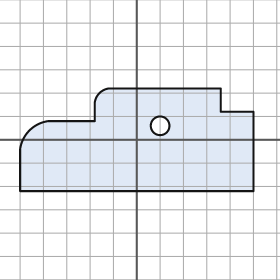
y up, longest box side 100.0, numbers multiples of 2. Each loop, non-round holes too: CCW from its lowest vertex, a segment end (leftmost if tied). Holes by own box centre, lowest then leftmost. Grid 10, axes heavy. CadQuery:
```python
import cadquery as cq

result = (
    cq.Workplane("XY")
    .moveTo(-50.0, -22.0)
    .lineTo(50.0, -22.0)
    .lineTo(50.0, 12.0)
    .lineTo(36.0, 12.0)
    .lineTo(36.0, 22.0)
    .lineTo(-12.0, 22.0)
    .threePointArc((-16.0, 20.0), (-18.0, 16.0))
    .lineTo(-18.0, 8.0)
    .lineTo(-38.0, 8.0)
    .threePointArc((-46.0, 4.0), (-50.0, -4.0))
    .close()
    .moveTo(10.0, 6.0)
    .circle(4.0)
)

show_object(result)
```